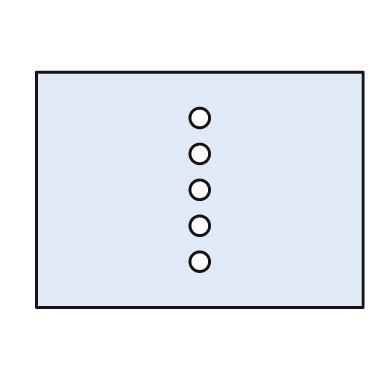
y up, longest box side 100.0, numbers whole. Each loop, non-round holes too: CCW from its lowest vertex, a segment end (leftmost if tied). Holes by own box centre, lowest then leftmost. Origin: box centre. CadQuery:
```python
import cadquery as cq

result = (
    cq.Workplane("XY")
    .moveTo(-50.0, -36.0)
    .lineTo(50.0, -36.0)
    .lineTo(50.0, 36.0)
    .lineTo(-50.0, 36.0)
    .close()
    .moveTo(0.0, -22.0)
    .circle(3.0)
    .moveTo(0.0, -11.0)
    .circle(3.0)
    .moveTo(0.0, 0.0)
    .circle(3.0)
    .moveTo(0.0, 11.0)
    .circle(3.0)
    .moveTo(0.0, 22.0)
    .circle(3.0)
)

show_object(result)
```